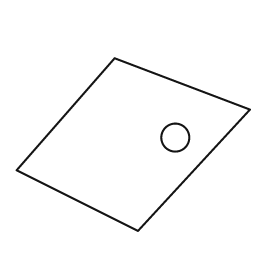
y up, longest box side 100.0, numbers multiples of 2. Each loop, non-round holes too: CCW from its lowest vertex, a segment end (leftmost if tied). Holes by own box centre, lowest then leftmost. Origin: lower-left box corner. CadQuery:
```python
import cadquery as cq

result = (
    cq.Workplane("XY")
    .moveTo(52.0, 0.0)
    .lineTo(100.0, 52.0)
    .lineTo(42.0, 74.0)
    .lineTo(0.0, 26.0)
    .close()
    .moveTo(68.0, 40.0)
    .circle(6.0)
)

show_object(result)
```